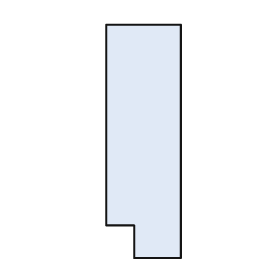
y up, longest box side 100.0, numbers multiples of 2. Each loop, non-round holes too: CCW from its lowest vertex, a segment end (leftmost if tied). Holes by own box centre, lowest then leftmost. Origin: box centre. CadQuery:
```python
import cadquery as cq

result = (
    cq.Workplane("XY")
    .moveTo(-4.0, -50.0)
    .lineTo(16.0, -50.0)
    .lineTo(16.0, 50.0)
    .lineTo(-16.0, 50.0)
    .lineTo(-16.0, -36.0)
    .lineTo(-4.0, -36.0)
    .close()
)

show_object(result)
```